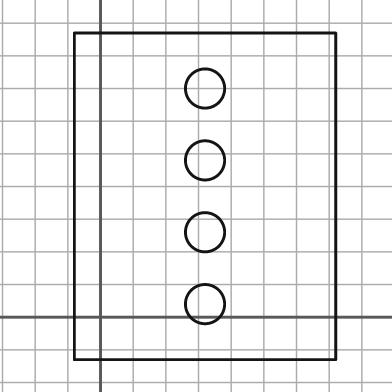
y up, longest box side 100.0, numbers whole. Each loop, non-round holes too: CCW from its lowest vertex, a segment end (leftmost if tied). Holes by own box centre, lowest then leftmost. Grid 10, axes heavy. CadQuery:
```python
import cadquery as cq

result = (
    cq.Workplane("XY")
    .moveTo(-8.0, -13.0)
    .lineTo(72.0, -13.0)
    .lineTo(72.0, 87.0)
    .lineTo(-8.0, 87.0)
    .close()
    .moveTo(32.0, 4.0)
    .circle(6.0)
    .moveTo(32.0, 26.0)
    .circle(6.0)
    .moveTo(32.0, 48.0)
    .circle(6.0)
    .moveTo(32.0, 70.0)
    .circle(6.0)
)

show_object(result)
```